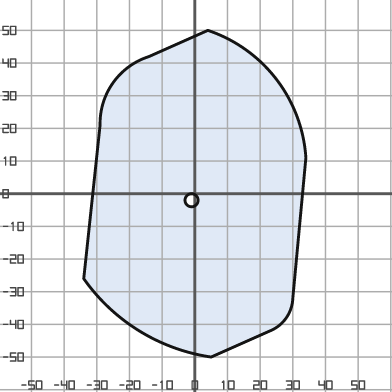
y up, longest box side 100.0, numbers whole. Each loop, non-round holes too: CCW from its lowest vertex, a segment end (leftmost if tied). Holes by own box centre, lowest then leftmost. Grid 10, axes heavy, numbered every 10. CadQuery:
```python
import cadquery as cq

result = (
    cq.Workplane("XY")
    .moveTo(5.0, -50.0)
    .lineTo(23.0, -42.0)
    .threePointArc((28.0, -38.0), (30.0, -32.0))
    .lineTo(34.0, 11.0)
    .threePointArc((25.0, 35.0), (4.0, 50.0))
    .lineTo(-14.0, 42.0)
    .threePointArc((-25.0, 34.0), (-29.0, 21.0))
    .lineTo(-34.0, -26.0)
    .threePointArc((-17.0, -42.0), (5.0, -50.0))
    .close()
    .moveTo(-1.0, -2.0)
    .circle(2.0)
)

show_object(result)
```